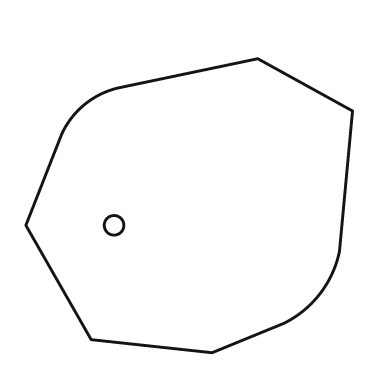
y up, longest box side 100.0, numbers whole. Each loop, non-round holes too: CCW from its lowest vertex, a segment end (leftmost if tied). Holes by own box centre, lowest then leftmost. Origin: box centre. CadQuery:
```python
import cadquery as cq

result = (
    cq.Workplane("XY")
    .moveTo(7.0, -45.0)
    .lineTo(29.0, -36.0)
    .threePointArc((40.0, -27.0), (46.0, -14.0))
    .lineTo(50.0, 29.0)
    .lineTo(21.0, 45.0)
    .lineTo(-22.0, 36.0)
    .threePointArc((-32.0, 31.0), (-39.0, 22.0))
    .lineTo(-50.0, -6.0)
    .lineTo(-30.0, -41.0)
    .close()
    .moveTo(-23.0, -6.0)
    .circle(3.0)
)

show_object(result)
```